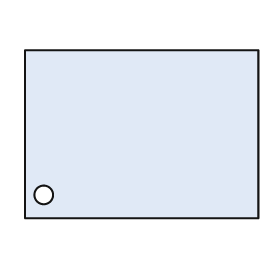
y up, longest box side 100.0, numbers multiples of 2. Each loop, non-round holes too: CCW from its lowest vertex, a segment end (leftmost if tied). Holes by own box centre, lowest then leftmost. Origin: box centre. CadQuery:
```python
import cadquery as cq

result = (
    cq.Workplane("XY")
    .moveTo(-50.0, -36.0)
    .lineTo(50.0, -36.0)
    .lineTo(50.0, 36.0)
    .lineTo(-50.0, 36.0)
    .close()
    .moveTo(-42.0, -26.0)
    .circle(4.0)
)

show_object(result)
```